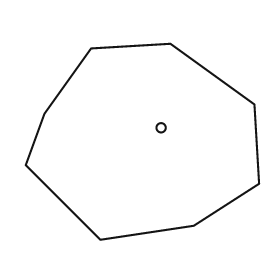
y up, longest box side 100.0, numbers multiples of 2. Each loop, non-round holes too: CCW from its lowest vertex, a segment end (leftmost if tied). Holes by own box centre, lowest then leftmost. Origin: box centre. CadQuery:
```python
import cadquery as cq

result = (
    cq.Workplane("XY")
    .moveTo(-18.0, -42.0)
    .lineTo(22.0, -36.0)
    .lineTo(50.0, -18.0)
    .lineTo(48.0, 16.0)
    .lineTo(12.0, 42.0)
    .lineTo(-22.0, 40.0)
    .lineTo(-42.0, 12.0)
    .lineTo(-50.0, -10.0)
    .close()
    .moveTo(8.0, 6.0)
    .circle(2.0)
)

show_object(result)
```